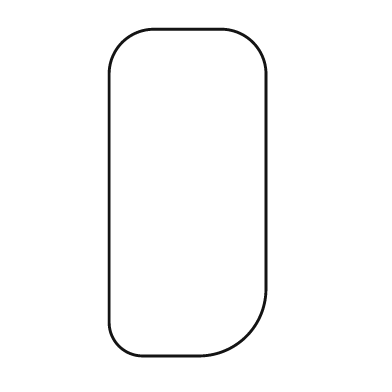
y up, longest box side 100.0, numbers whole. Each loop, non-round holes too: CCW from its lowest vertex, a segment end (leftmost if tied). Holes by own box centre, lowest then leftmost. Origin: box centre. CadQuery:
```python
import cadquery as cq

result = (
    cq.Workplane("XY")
    .moveTo(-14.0, -50.0)
    .lineTo(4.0, -50.0)
    .threePointArc((18.0, -44.0), (24.0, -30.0))
    .lineTo(24.0, 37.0)
    .threePointArc((20.0, 46.0), (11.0, 50.0))
    .lineTo(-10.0, 50.0)
    .threePointArc((-20.0, 46.0), (-24.0, 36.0))
    .lineTo(-24.0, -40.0)
    .threePointArc((-21.0, -47.0), (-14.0, -50.0))
    .close()
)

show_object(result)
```